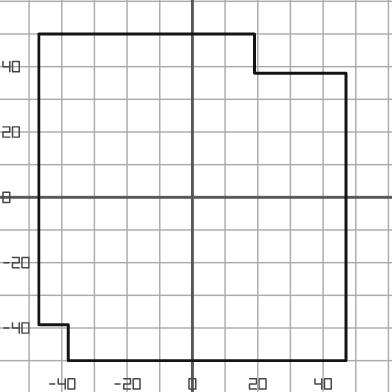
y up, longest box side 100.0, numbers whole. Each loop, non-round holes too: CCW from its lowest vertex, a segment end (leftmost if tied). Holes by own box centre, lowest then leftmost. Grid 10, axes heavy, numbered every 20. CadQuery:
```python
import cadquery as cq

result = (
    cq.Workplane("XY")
    .moveTo(-38.0, -50.0)
    .lineTo(47.0, -50.0)
    .lineTo(47.0, 38.0)
    .lineTo(19.0, 38.0)
    .lineTo(19.0, 50.0)
    .lineTo(-47.0, 50.0)
    .lineTo(-47.0, -39.0)
    .lineTo(-38.0, -39.0)
    .close()
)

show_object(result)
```